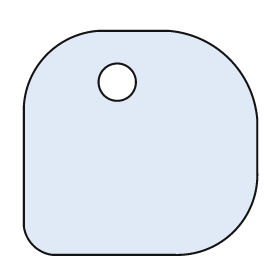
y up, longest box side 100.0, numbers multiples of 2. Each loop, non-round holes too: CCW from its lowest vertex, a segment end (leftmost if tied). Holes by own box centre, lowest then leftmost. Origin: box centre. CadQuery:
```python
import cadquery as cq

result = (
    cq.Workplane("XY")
    .moveTo(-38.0, -48.0)
    .lineTo(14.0, -48.0)
    .threePointArc((40.0, -38.0), (50.0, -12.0))
    .lineTo(50.0, 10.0)
    .threePointArc((38.0, 36.0), (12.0, 48.0))
    .lineTo(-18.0, 48.0)
    .threePointArc((-40.0, 38.0), (-50.0, 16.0))
    .lineTo(-50.0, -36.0)
    .threePointArc((-46.0, -44.0), (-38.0, -48.0))
    .close()
    .moveTo(-10.0, 26.0)
    .circle(8.0)
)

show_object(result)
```